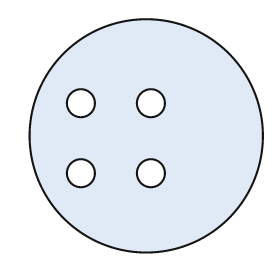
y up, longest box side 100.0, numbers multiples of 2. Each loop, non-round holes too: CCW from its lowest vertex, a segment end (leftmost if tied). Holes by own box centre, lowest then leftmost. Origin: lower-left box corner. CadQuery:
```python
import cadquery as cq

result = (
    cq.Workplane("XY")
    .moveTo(50.0, 50.0)
    .circle(50.0)
    .moveTo(22.0, 34.0)
    .circle(6.0)
    .moveTo(52.0, 34.0)
    .circle(6.0)
    .moveTo(22.0, 64.0)
    .circle(6.0)
    .moveTo(52.0, 64.0)
    .circle(6.0)
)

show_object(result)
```